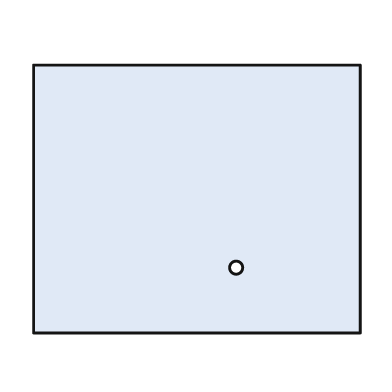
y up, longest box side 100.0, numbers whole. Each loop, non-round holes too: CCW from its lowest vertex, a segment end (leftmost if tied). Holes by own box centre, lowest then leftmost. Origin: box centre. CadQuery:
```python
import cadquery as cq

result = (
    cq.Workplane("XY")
    .moveTo(-50.0, -41.0)
    .lineTo(50.0, -41.0)
    .lineTo(50.0, 41.0)
    .lineTo(-50.0, 41.0)
    .close()
    .moveTo(12.0, -21.0)
    .circle(2.0)
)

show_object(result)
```